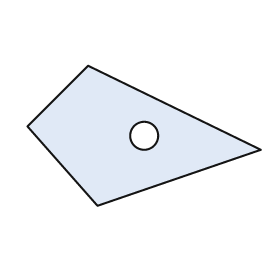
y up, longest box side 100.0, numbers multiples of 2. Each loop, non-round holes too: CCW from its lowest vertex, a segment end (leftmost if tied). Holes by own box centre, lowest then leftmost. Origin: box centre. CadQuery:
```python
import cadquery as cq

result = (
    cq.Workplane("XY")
    .moveTo(-20.0, -30.0)
    .lineTo(50.0, -6.0)
    .lineTo(-24.0, 30.0)
    .lineTo(-50.0, 4.0)
    .close()
    .moveTo(0.0, 0.0)
    .circle(6.0)
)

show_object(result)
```